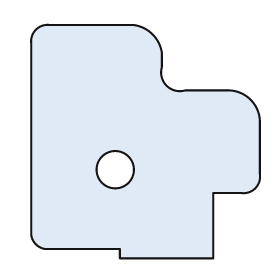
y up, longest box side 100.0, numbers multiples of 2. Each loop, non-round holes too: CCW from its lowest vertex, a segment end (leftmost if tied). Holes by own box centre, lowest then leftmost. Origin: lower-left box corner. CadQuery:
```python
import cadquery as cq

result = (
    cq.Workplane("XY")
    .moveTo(38.0, 0.0)
    .lineTo(78.0, 0.0)
    .lineTo(78.0, 28.0)
    .lineTo(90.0, 28.0)
    .threePointArc((96.0, 30.0), (98.0, 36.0))
    .lineTo(98.0, 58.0)
    .threePointArc((94.0, 68.0), (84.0, 72.0))
    .lineTo(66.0, 72.0)
    .threePointArc((58.0, 74.0), (56.0, 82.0))
    .lineTo(56.0, 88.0)
    .threePointArc((52.0, 96.0), (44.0, 100.0))
    .lineTo(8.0, 100.0)
    .threePointArc((2.0, 98.0), (0.0, 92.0))
    .lineTo(0.0, 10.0)
    .threePointArc((2.0, 6.0), (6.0, 4.0))
    .lineTo(38.0, 4.0)
    .close()
    .moveTo(36.0, 38.0)
    .circle(8.0)
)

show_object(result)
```